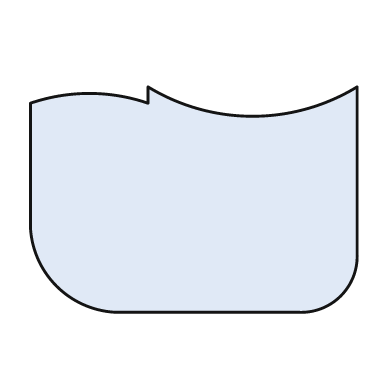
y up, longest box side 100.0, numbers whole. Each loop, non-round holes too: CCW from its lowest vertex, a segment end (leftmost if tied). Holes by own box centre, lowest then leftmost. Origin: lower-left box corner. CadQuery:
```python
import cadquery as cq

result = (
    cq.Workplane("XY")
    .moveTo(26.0, 0.0)
    .lineTo(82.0, 0.0)
    .threePointArc((95.0, 5.0), (100.0, 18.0))
    .lineTo(100.0, 69.0)
    .threePointArc((68.0, 60.0), (36.0, 69.0))
    .lineTo(36.0, 64.0)
    .threePointArc((18.0, 67.0), (0.0, 64.0))
    .lineTo(0.0, 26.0)
    .threePointArc((8.0, 8.0), (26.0, 0.0))
    .close()
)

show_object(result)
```